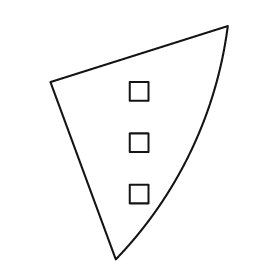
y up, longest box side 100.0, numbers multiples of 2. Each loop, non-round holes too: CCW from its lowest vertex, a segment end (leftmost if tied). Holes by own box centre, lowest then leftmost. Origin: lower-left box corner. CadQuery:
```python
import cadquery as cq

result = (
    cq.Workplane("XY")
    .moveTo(28.0, 0.0)
    .threePointArc((60.0, 46.0), (76.0, 100.0))
    .lineTo(0.0, 76.0)
    .close()
    .moveTo(34.0, 24.0)
    .lineTo(42.0, 24.0)
    .lineTo(42.0, 32.0)
    .lineTo(34.0, 32.0)
    .close()
    .moveTo(34.0, 46.0)
    .lineTo(42.0, 46.0)
    .lineTo(42.0, 54.0)
    .lineTo(34.0, 54.0)
    .close()
    .moveTo(34.0, 68.0)
    .lineTo(42.0, 68.0)
    .lineTo(42.0, 76.0)
    .lineTo(34.0, 76.0)
    .close()
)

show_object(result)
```